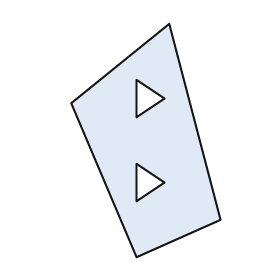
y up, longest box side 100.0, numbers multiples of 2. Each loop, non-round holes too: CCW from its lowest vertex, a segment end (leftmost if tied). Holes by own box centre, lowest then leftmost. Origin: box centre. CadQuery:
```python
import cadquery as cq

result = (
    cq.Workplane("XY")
    .moveTo(-4.0, -50.0)
    .lineTo(32.0, -34.0)
    .lineTo(10.0, 50.0)
    .lineTo(-32.0, 16.0)
    .close()
    .moveTo(-4.0, -26.0)
    .lineTo(8.0, -18.0)
    .lineTo(-4.0, -10.0)
    .close()
    .moveTo(-4.0, 10.0)
    .lineTo(8.0, 18.0)
    .lineTo(-4.0, 26.0)
    .close()
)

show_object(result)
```